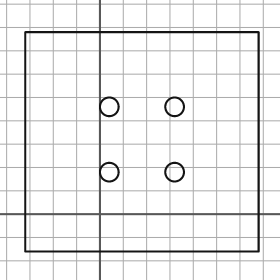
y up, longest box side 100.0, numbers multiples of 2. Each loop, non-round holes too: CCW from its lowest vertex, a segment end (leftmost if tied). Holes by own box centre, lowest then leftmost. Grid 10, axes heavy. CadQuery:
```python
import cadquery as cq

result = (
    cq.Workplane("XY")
    .moveTo(-32.0, -16.0)
    .lineTo(68.0, -16.0)
    .lineTo(68.0, 78.0)
    .lineTo(-32.0, 78.0)
    .close()
    .moveTo(4.0, 18.0)
    .circle(4.0)
    .moveTo(32.0, 18.0)
    .circle(4.0)
    .moveTo(4.0, 46.0)
    .circle(4.0)
    .moveTo(32.0, 46.0)
    .circle(4.0)
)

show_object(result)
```